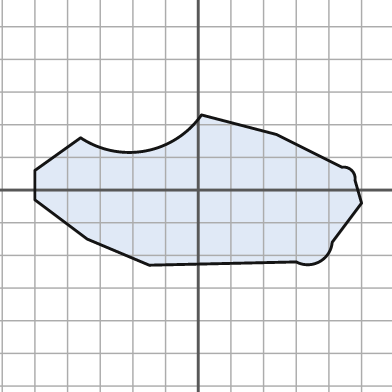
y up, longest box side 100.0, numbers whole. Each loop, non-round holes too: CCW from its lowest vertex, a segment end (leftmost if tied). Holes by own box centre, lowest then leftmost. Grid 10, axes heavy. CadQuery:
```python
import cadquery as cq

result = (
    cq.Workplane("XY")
    .moveTo(-15.0, -23.0)
    .lineTo(30.0, -22.0)
    .threePointArc((37.0, -22.0), (41.0, -16.0))
    .lineTo(50.0, -4.0)
    .lineTo(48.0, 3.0)
    .threePointArc((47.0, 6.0), (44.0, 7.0))
    .lineTo(24.0, 17.0)
    .lineTo(1.0, 23.0)
    .threePointArc((-16.0, 12.0), (-36.0, 16.0))
    .lineTo(-50.0, 6.0)
    .lineTo(-50.0, -3.0)
    .lineTo(-34.0, -15.0)
    .close()
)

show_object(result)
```